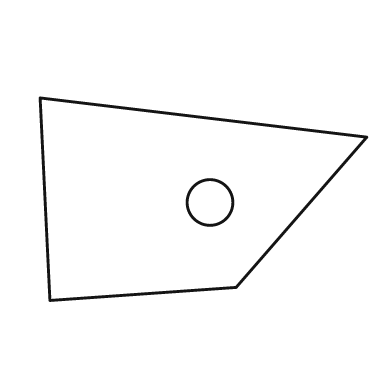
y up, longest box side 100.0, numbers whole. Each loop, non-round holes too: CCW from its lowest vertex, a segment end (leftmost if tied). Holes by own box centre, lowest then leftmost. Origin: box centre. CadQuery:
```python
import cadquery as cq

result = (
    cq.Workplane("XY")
    .moveTo(-47.0, -31.0)
    .lineTo(10.0, -27.0)
    .lineTo(50.0, 19.0)
    .lineTo(-50.0, 31.0)
    .close()
    .moveTo(2.0, -1.0)
    .circle(7.0)
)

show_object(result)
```